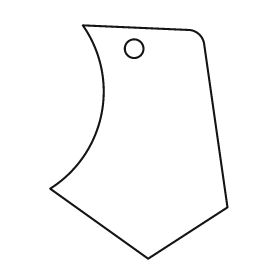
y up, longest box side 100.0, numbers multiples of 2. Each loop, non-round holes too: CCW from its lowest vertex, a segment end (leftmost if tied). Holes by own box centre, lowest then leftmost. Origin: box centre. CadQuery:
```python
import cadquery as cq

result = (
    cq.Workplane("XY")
    .moveTo(4.0, -50.0)
    .lineTo(38.0, -28.0)
    .lineTo(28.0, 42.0)
    .threePointArc((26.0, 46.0), (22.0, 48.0))
    .lineTo(-24.0, 50.0)
    .threePointArc((-16.0, 12.0), (-38.0, -20.0))
    .close()
    .moveTo(-2.0, 40.0)
    .circle(4.0)
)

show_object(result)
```